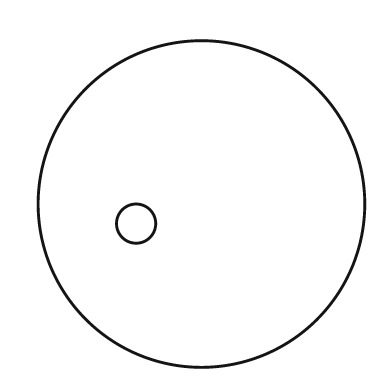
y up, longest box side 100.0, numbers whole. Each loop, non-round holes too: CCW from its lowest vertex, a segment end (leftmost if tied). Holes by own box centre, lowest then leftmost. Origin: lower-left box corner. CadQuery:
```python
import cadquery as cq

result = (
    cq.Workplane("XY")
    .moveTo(50.0, 50.0)
    .circle(50.0)
    .moveTo(30.0, 44.0)
    .circle(6.0)
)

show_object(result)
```